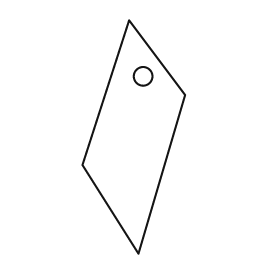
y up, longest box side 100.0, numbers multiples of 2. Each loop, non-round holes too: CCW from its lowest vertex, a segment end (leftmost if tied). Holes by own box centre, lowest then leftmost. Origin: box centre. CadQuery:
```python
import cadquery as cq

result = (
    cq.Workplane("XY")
    .moveTo(2.0, -50.0)
    .lineTo(22.0, 18.0)
    .lineTo(-2.0, 50.0)
    .lineTo(-22.0, -12.0)
    .close()
    .moveTo(4.0, 26.0)
    .circle(4.0)
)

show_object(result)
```